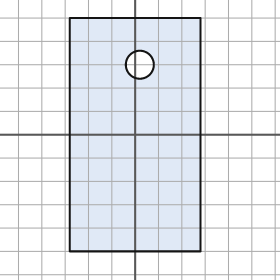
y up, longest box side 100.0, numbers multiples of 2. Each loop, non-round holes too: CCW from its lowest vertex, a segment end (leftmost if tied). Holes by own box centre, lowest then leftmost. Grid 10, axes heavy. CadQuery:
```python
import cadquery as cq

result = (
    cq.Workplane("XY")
    .moveTo(-28.0, -50.0)
    .lineTo(28.0, -50.0)
    .lineTo(28.0, 50.0)
    .lineTo(-28.0, 50.0)
    .close()
    .moveTo(2.0, 30.0)
    .circle(6.0)
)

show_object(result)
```